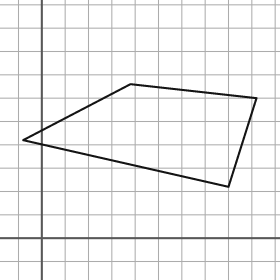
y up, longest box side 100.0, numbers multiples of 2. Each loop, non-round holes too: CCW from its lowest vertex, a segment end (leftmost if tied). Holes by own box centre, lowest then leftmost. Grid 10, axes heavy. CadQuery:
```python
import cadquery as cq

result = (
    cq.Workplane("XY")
    .moveTo(80.0, 22.0)
    .lineTo(92.0, 60.0)
    .lineTo(38.0, 66.0)
    .lineTo(-8.0, 42.0)
    .close()
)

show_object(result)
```